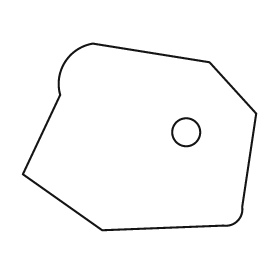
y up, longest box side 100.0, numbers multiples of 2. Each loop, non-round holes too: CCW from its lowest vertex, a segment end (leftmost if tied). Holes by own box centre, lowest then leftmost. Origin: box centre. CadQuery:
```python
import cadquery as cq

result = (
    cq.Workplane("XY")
    .moveTo(-16.0, -40.0)
    .lineTo(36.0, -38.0)
    .threePointArc((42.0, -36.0), (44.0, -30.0))
    .lineTo(50.0, 10.0)
    .lineTo(30.0, 32.0)
    .lineTo(-20.0, 40.0)
    .threePointArc((-32.0, 32.0), (-34.0, 18.0))
    .lineTo(-50.0, -16.0)
    .close()
    .moveTo(20.0, 2.0)
    .circle(6.0)
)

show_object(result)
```